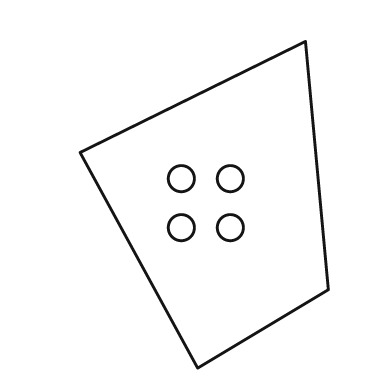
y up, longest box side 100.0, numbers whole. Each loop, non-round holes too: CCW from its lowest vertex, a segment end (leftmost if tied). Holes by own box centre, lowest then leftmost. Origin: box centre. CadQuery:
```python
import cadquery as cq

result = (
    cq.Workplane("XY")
    .moveTo(-2.0, -50.0)
    .lineTo(38.0, -26.0)
    .lineTo(31.0, 50.0)
    .lineTo(-38.0, 16.0)
    .close()
    .moveTo(-7.0, -7.0)
    .circle(4.0)
    .moveTo(8.0, -7.0)
    .circle(4.0)
    .moveTo(-7.0, 8.0)
    .circle(4.0)
    .moveTo(8.0, 8.0)
    .circle(4.0)
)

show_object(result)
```